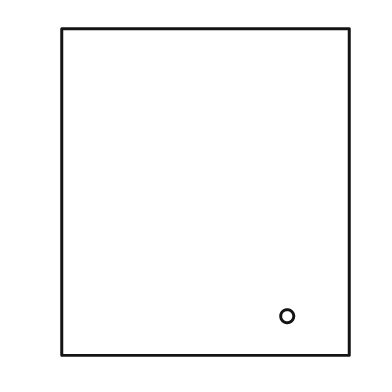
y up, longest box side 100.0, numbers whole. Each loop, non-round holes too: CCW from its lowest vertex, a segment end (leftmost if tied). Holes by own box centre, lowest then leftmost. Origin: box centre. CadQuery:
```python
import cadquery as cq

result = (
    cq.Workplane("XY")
    .moveTo(-44.0, -50.0)
    .lineTo(44.0, -50.0)
    .lineTo(44.0, 50.0)
    .lineTo(-44.0, 50.0)
    .close()
    .moveTo(25.0, -38.0)
    .circle(2.0)
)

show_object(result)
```